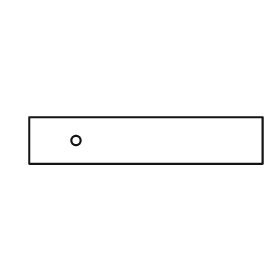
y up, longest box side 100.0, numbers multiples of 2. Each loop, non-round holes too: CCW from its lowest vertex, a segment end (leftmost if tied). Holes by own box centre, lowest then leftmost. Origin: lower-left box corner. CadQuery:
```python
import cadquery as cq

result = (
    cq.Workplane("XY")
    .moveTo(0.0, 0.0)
    .lineTo(100.0, 0.0)
    .lineTo(100.0, 20.0)
    .lineTo(0.0, 20.0)
    .close()
    .moveTo(20.0, 10.0)
    .circle(2.0)
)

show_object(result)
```